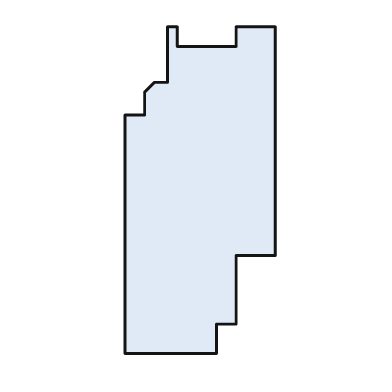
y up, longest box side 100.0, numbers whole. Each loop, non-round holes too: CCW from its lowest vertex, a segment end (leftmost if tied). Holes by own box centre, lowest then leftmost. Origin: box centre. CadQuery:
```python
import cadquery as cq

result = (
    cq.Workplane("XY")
    .moveTo(-23.0, -50.0)
    .lineTo(5.0, -50.0)
    .lineTo(5.0, -41.0)
    .lineTo(11.0, -41.0)
    .lineTo(11.0, -20.0)
    .lineTo(23.0, -20.0)
    .lineTo(23.0, 50.0)
    .lineTo(11.0, 50.0)
    .lineTo(11.0, 44.0)
    .lineTo(-7.0, 44.0)
    .lineTo(-7.0, 50.0)
    .lineTo(-10.0, 50.0)
    .lineTo(-10.0, 33.0)
    .lineTo(-14.0, 33.0)
    .lineTo(-17.0, 30.0)
    .lineTo(-17.0, 23.0)
    .lineTo(-23.0, 23.0)
    .close()
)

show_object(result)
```